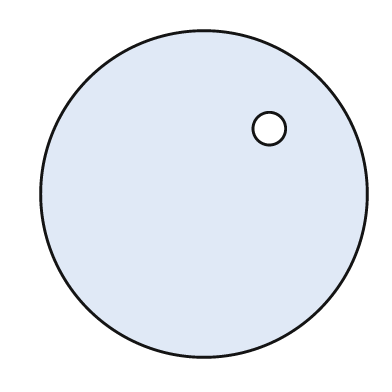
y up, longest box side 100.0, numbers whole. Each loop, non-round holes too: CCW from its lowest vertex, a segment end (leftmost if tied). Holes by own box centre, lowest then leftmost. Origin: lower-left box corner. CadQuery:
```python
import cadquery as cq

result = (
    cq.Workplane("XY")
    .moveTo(50.0, 50.0)
    .circle(50.0)
    .moveTo(70.0, 70.0)
    .circle(5.0)
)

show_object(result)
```